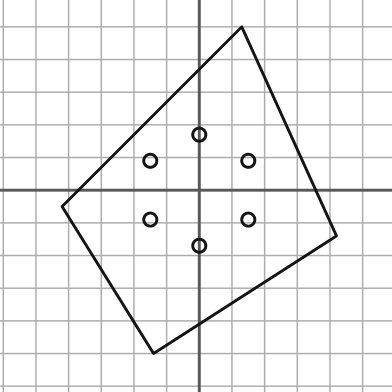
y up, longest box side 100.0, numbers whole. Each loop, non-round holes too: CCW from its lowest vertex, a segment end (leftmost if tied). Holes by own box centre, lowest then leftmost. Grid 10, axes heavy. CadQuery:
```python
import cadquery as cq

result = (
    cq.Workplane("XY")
    .moveTo(-14.0, -50.0)
    .lineTo(42.0, -14.0)
    .lineTo(13.0, 50.0)
    .lineTo(-42.0, -5.0)
    .close()
    .moveTo(0.0, -17.0)
    .circle(2.0)
    .moveTo(-15.0, -9.0)
    .circle(2.0)
    .moveTo(15.0, -9.0)
    .circle(2.0)
    .moveTo(-15.0, 9.0)
    .circle(2.0)
    .moveTo(15.0, 9.0)
    .circle(2.0)
    .moveTo(0.0, 17.0)
    .circle(2.0)
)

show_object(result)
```